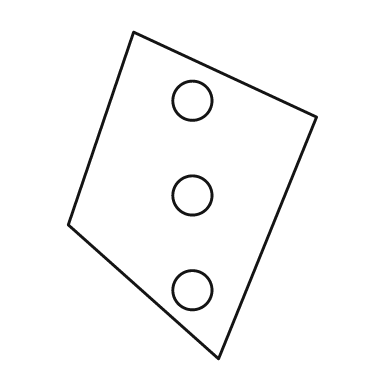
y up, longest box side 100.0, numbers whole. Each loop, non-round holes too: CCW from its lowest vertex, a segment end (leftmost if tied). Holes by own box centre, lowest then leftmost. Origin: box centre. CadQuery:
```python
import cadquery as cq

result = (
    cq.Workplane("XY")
    .moveTo(8.0, -50.0)
    .lineTo(38.0, 24.0)
    .lineTo(-18.0, 50.0)
    .lineTo(-38.0, -9.0)
    .close()
    .moveTo(0.0, -29.0)
    .circle(6.0)
    .moveTo(0.0, 0.0)
    .circle(6.0)
    .moveTo(0.0, 29.0)
    .circle(6.0)
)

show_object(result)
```